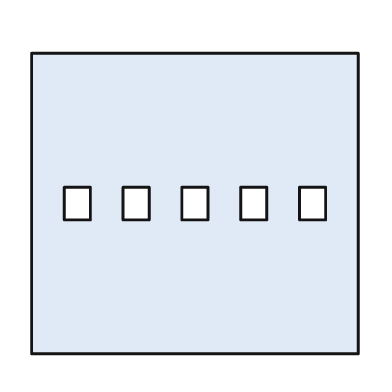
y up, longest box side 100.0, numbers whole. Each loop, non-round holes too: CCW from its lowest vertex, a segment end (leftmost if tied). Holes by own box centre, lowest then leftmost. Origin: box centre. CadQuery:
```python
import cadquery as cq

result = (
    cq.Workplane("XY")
    .moveTo(-50.0, -46.0)
    .lineTo(50.0, -46.0)
    .lineTo(50.0, 46.0)
    .lineTo(-50.0, 46.0)
    .close()
    .moveTo(-40.0, -5.0)
    .lineTo(-32.0, -5.0)
    .lineTo(-32.0, 5.0)
    .lineTo(-40.0, 5.0)
    .close()
    .moveTo(-22.0, -5.0)
    .lineTo(-14.0, -5.0)
    .lineTo(-14.0, 5.0)
    .lineTo(-22.0, 5.0)
    .close()
    .moveTo(-4.0, -5.0)
    .lineTo(4.0, -5.0)
    .lineTo(4.0, 5.0)
    .lineTo(-4.0, 5.0)
    .close()
    .moveTo(14.0, -5.0)
    .lineTo(22.0, -5.0)
    .lineTo(22.0, 5.0)
    .lineTo(14.0, 5.0)
    .close()
    .moveTo(32.0, -5.0)
    .lineTo(40.0, -5.0)
    .lineTo(40.0, 5.0)
    .lineTo(32.0, 5.0)
    .close()
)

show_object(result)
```